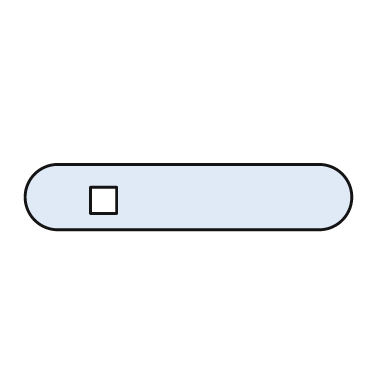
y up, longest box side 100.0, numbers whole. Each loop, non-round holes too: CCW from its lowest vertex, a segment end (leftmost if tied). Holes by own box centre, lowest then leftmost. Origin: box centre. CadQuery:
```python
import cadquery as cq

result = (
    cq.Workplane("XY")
    .moveTo(-40.0, -10.0)
    .lineTo(40.0, -10.0)
    .threePointArc((50.0, 0.0), (40.0, 10.0))
    .lineTo(-40.0, 10.0)
    .threePointArc((-50.0, 0.0), (-40.0, -10.0))
    .close()
    .moveTo(-30.0, -5.0)
    .lineTo(-22.0, -5.0)
    .lineTo(-22.0, 3.0)
    .lineTo(-30.0, 3.0)
    .close()
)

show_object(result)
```